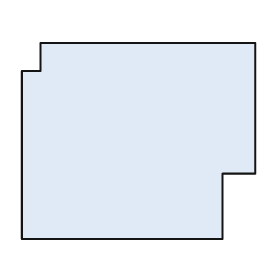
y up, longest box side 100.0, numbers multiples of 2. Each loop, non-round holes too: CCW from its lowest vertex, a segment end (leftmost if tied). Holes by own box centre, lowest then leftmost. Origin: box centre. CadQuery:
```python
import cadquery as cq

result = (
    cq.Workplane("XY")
    .moveTo(-50.0, -42.0)
    .lineTo(36.0, -42.0)
    .lineTo(36.0, -14.0)
    .lineTo(50.0, -14.0)
    .lineTo(50.0, 42.0)
    .lineTo(-42.0, 42.0)
    .lineTo(-42.0, 30.0)
    .lineTo(-50.0, 30.0)
    .close()
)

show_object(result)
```